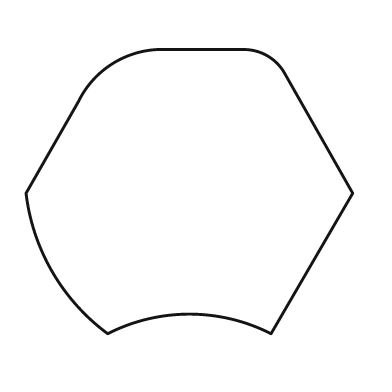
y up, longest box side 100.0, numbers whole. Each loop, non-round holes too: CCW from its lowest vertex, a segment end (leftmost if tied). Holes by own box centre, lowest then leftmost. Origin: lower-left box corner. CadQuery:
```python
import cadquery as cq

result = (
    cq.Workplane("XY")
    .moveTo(25.0, 0.0)
    .threePointArc((50.0, 6.0), (75.0, 0.0))
    .lineTo(100.0, 43.0)
    .lineTo(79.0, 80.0)
    .threePointArc((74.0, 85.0), (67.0, 87.0))
    .lineTo(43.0, 87.0)
    .threePointArc((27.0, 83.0), (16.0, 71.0))
    .lineTo(0.0, 43.0)
    .threePointArc((8.0, 19.0), (25.0, 0.0))
    .close()
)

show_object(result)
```